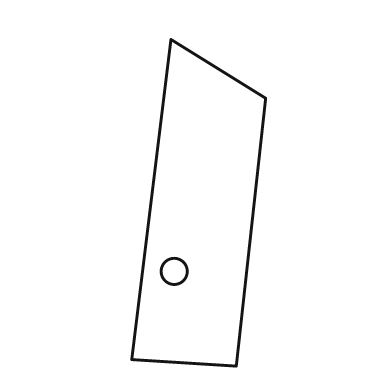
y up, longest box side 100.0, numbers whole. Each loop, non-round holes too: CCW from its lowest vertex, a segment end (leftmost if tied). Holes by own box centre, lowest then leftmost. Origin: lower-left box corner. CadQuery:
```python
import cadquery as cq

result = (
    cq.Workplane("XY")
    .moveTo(32.0, 0.0)
    .lineTo(41.0, 82.0)
    .lineTo(12.0, 100.0)
    .lineTo(0.0, 2.0)
    .close()
    .moveTo(13.0, 29.0)
    .circle(4.0)
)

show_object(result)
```